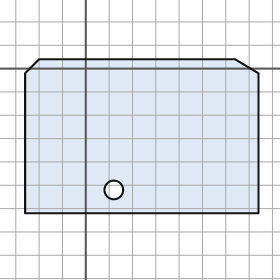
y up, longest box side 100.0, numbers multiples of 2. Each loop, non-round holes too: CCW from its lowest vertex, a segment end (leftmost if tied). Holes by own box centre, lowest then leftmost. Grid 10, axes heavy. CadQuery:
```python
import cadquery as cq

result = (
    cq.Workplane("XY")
    .moveTo(-26.0, -62.0)
    .lineTo(74.0, -62.0)
    .lineTo(74.0, -2.0)
    .lineTo(64.0, 4.0)
    .lineTo(-20.0, 4.0)
    .lineTo(-26.0, -2.0)
    .close()
    .moveTo(12.0, -52.0)
    .circle(4.0)
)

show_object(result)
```